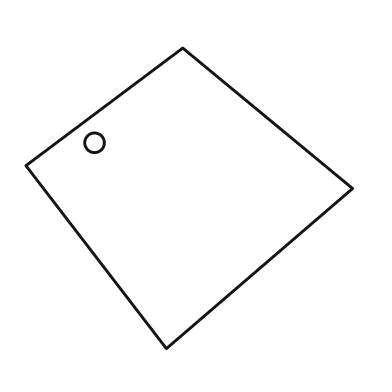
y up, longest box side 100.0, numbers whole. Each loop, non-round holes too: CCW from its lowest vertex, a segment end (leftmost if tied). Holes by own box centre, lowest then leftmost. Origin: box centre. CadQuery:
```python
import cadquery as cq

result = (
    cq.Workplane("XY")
    .moveTo(-7.0, -46.0)
    .lineTo(50.0, 3.0)
    .lineTo(-2.0, 46.0)
    .lineTo(-50.0, 10.0)
    .close()
    .moveTo(-29.0, 17.0)
    .circle(3.0)
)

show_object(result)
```